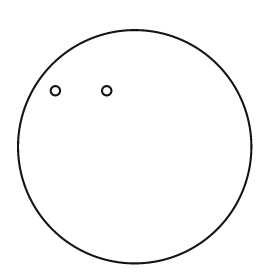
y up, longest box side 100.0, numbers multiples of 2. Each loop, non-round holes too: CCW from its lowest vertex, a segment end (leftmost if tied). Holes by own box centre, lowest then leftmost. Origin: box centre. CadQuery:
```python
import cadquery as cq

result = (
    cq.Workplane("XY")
    .moveTo(0.0, 0.0)
    .circle(50.0)
    .moveTo(-34.0, 24.0)
    .circle(2.0)
    .moveTo(-12.0, 24.0)
    .circle(2.0)
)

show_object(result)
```